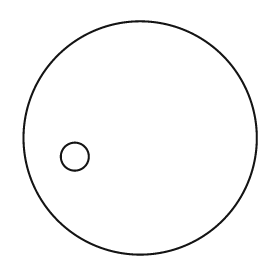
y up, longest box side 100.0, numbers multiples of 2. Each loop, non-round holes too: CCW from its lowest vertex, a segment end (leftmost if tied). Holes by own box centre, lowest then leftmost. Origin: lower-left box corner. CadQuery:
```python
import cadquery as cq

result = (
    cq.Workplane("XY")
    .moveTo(50.0, 50.0)
    .circle(50.0)
    .moveTo(22.0, 42.0)
    .circle(6.0)
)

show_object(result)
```